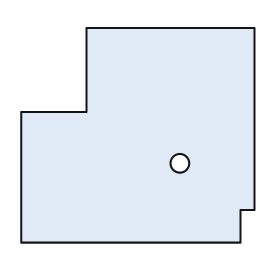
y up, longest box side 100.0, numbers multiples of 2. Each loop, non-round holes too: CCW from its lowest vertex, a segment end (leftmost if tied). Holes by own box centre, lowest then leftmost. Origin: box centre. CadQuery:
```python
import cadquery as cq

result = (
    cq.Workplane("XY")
    .moveTo(-50.0, -46.0)
    .lineTo(44.0, -46.0)
    .lineTo(44.0, -32.0)
    .lineTo(50.0, -32.0)
    .lineTo(50.0, 46.0)
    .lineTo(-22.0, 46.0)
    .lineTo(-22.0, 10.0)
    .lineTo(-50.0, 10.0)
    .close()
    .moveTo(18.0, -12.0)
    .circle(4.0)
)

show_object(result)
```